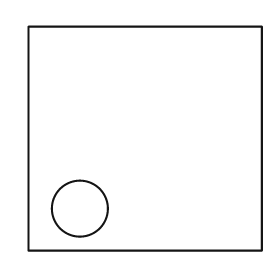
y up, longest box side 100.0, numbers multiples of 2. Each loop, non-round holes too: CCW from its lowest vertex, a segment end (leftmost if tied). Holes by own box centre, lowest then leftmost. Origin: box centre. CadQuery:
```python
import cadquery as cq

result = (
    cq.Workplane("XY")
    .moveTo(-50.0, -48.0)
    .lineTo(50.0, -48.0)
    .lineTo(50.0, 48.0)
    .lineTo(-50.0, 48.0)
    .close()
    .moveTo(-28.0, -30.0)
    .circle(12.0)
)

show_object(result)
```